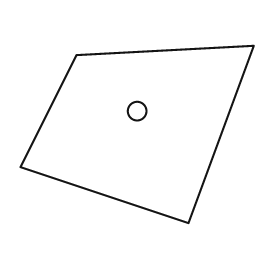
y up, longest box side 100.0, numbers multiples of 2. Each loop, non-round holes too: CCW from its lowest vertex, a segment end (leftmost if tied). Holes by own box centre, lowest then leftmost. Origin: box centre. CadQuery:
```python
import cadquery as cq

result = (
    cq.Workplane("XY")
    .moveTo(22.0, -38.0)
    .lineTo(50.0, 38.0)
    .lineTo(-26.0, 34.0)
    .lineTo(-50.0, -14.0)
    .close()
    .moveTo(0.0, 10.0)
    .circle(4.0)
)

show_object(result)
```